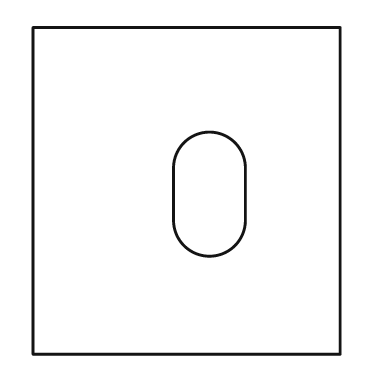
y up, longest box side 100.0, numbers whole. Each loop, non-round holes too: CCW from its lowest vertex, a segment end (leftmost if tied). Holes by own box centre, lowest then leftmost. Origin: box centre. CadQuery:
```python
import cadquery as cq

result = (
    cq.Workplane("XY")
    .moveTo(-47.0, -50.0)
    .lineTo(47.0, -50.0)
    .lineTo(47.0, 50.0)
    .lineTo(-47.0, 50.0)
    .close()
    .moveTo(-4.0, -9.0)
    .threePointArc((7.0, -20.0), (18.0, -9.0))
    .lineTo(18.0, 7.0)
    .threePointArc((7.0, 18.0), (-4.0, 7.0))
    .close()
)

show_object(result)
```